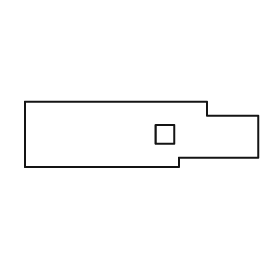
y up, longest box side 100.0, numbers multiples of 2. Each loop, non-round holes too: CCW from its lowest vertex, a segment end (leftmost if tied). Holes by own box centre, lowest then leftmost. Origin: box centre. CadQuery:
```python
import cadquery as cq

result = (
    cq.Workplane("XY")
    .moveTo(-50.0, -14.0)
    .lineTo(16.0, -14.0)
    .lineTo(16.0, -10.0)
    .lineTo(50.0, -10.0)
    .lineTo(50.0, 8.0)
    .lineTo(28.0, 8.0)
    .lineTo(28.0, 14.0)
    .lineTo(-50.0, 14.0)
    .close()
    .moveTo(6.0, -4.0)
    .lineTo(14.0, -4.0)
    .lineTo(14.0, 4.0)
    .lineTo(6.0, 4.0)
    .close()
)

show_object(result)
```